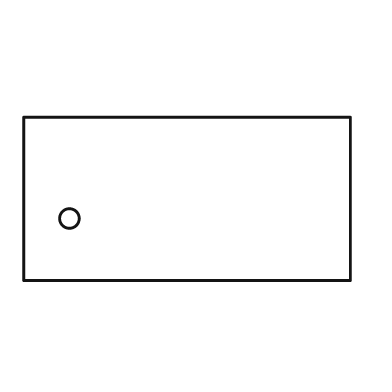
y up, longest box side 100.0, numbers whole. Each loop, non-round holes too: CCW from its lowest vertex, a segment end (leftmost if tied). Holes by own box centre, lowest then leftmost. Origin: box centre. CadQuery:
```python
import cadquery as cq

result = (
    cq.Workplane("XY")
    .moveTo(-50.0, -25.0)
    .lineTo(50.0, -25.0)
    .lineTo(50.0, 25.0)
    .lineTo(-50.0, 25.0)
    .close()
    .moveTo(-36.0, -6.0)
    .circle(3.0)
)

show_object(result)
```